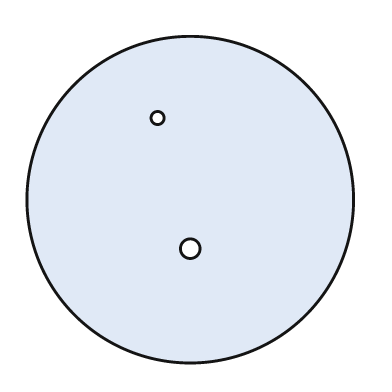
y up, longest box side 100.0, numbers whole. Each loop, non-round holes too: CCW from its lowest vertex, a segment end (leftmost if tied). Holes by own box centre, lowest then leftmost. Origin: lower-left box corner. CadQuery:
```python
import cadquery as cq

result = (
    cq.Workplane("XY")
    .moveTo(50.0, 50.0)
    .circle(50.0)
    .moveTo(50.0, 35.0)
    .circle(3.0)
    .moveTo(40.0, 75.0)
    .circle(2.0)
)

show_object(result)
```